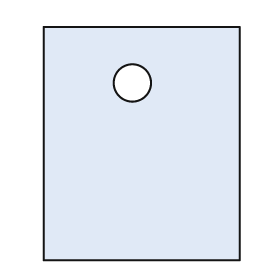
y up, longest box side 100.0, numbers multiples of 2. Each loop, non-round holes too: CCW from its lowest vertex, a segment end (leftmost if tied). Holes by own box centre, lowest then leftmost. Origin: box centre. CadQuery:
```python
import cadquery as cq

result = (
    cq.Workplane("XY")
    .moveTo(-42.0, -50.0)
    .lineTo(42.0, -50.0)
    .lineTo(42.0, 50.0)
    .lineTo(-42.0, 50.0)
    .close()
    .moveTo(-4.0, 26.0)
    .circle(8.0)
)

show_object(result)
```